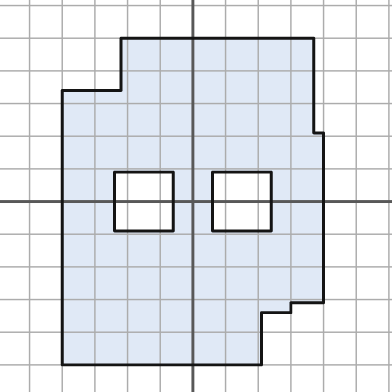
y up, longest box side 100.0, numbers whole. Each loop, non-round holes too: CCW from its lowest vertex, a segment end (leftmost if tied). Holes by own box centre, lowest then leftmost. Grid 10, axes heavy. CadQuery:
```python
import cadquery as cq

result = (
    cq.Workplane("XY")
    .moveTo(-40.0, -50.0)
    .lineTo(21.0, -50.0)
    .lineTo(21.0, -34.0)
    .lineTo(30.0, -34.0)
    .lineTo(30.0, -31.0)
    .lineTo(40.0, -31.0)
    .lineTo(40.0, 21.0)
    .lineTo(37.0, 21.0)
    .lineTo(37.0, 50.0)
    .lineTo(-22.0, 50.0)
    .lineTo(-22.0, 34.0)
    .lineTo(-40.0, 34.0)
    .close()
    .moveTo(-24.0, -9.0)
    .lineTo(-6.0, -9.0)
    .lineTo(-6.0, 9.0)
    .lineTo(-24.0, 9.0)
    .close()
    .moveTo(6.0, -9.0)
    .lineTo(24.0, -9.0)
    .lineTo(24.0, 9.0)
    .lineTo(6.0, 9.0)
    .close()
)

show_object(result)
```